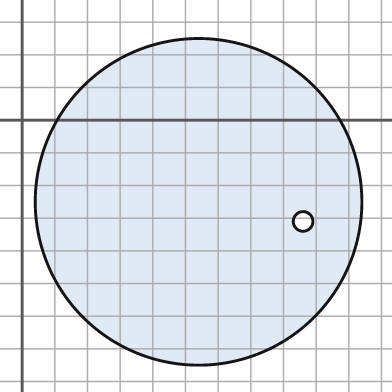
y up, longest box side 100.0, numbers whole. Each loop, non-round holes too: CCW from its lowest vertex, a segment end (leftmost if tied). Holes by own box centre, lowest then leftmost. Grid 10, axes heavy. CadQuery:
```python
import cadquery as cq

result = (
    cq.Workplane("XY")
    .moveTo(54.0, -25.0)
    .circle(50.0)
    .moveTo(86.0, -31.0)
    .circle(3.0)
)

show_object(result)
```